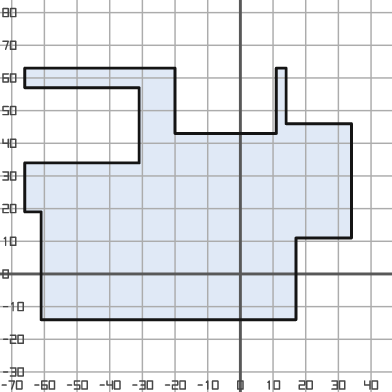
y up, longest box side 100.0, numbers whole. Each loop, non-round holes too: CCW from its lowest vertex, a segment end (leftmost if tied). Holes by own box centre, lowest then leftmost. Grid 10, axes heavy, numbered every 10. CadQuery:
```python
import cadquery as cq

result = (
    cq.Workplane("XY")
    .moveTo(-61.0, -14.0)
    .lineTo(17.0, -14.0)
    .lineTo(17.0, 11.0)
    .lineTo(34.0, 11.0)
    .lineTo(34.0, 46.0)
    .lineTo(14.0, 46.0)
    .lineTo(14.0, 63.0)
    .lineTo(11.0, 63.0)
    .lineTo(11.0, 43.0)
    .lineTo(-20.0, 43.0)
    .lineTo(-20.0, 63.0)
    .lineTo(-66.0, 63.0)
    .lineTo(-66.0, 57.0)
    .lineTo(-31.0, 57.0)
    .lineTo(-31.0, 34.0)
    .lineTo(-66.0, 34.0)
    .lineTo(-66.0, 19.0)
    .lineTo(-61.0, 19.0)
    .close()
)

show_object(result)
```